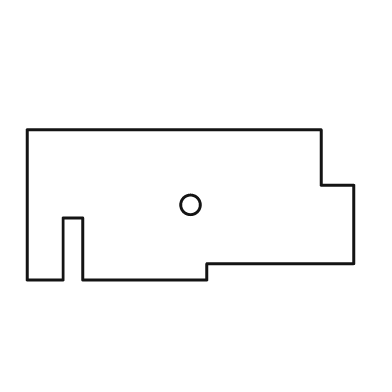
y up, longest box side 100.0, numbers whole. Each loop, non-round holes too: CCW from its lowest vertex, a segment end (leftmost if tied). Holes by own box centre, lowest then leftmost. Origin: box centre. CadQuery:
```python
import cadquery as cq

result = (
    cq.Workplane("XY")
    .moveTo(-50.0, -23.0)
    .lineTo(-39.0, -23.0)
    .lineTo(-39.0, -4.0)
    .lineTo(-33.0, -4.0)
    .lineTo(-33.0, -23.0)
    .lineTo(5.0, -23.0)
    .lineTo(5.0, -18.0)
    .lineTo(50.0, -18.0)
    .lineTo(50.0, 6.0)
    .lineTo(40.0, 6.0)
    .lineTo(40.0, 23.0)
    .lineTo(-50.0, 23.0)
    .close()
    .moveTo(0.0, 0.0)
    .circle(3.0)
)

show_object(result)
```